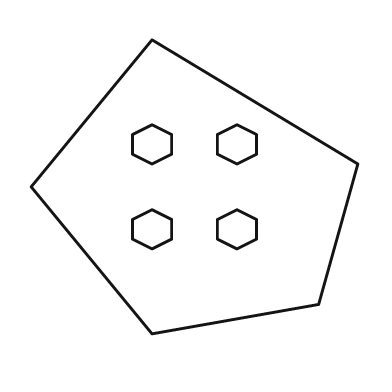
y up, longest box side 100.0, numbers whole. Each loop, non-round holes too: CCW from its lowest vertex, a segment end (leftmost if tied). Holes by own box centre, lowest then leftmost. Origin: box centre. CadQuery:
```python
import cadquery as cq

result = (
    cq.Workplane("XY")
    .moveTo(-13.0, -45.0)
    .lineTo(38.0, -36.0)
    .lineTo(50.0, 7.0)
    .lineTo(-13.0, 45.0)
    .lineTo(-50.0, 0.0)
    .close()
    .moveTo(-13.0, -19.0)
    .lineTo(-7.0, -16.0)
    .lineTo(-7.0, -10.0)
    .lineTo(-13.0, -7.0)
    .lineTo(-19.0, -10.0)
    .lineTo(-19.0, -16.0)
    .close()
    .moveTo(13.0, -19.0)
    .lineTo(19.0, -16.0)
    .lineTo(19.0, -10.0)
    .lineTo(13.0, -7.0)
    .lineTo(7.0, -10.0)
    .lineTo(7.0, -16.0)
    .close()
    .moveTo(-13.0, 7.0)
    .lineTo(-7.0, 10.0)
    .lineTo(-7.0, 16.0)
    .lineTo(-13.0, 19.0)
    .lineTo(-19.0, 16.0)
    .lineTo(-19.0, 10.0)
    .close()
    .moveTo(13.0, 7.0)
    .lineTo(19.0, 10.0)
    .lineTo(19.0, 16.0)
    .lineTo(13.0, 19.0)
    .lineTo(7.0, 16.0)
    .lineTo(7.0, 10.0)
    .close()
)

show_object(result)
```